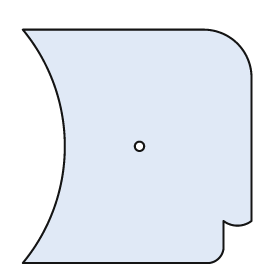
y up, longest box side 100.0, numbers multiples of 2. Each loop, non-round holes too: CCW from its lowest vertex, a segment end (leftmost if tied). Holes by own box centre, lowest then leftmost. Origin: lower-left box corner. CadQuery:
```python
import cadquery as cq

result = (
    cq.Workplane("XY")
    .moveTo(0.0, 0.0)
    .lineTo(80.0, 0.0)
    .threePointArc((84.0, 2.0), (86.0, 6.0))
    .lineTo(86.0, 18.0)
    .threePointArc((92.0, 16.0), (98.0, 18.0))
    .lineTo(98.0, 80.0)
    .threePointArc((92.0, 94.0), (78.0, 100.0))
    .lineTo(0.0, 100.0)
    .threePointArc((18.0, 50.0), (0.0, 0.0))
    .close()
    .moveTo(50.0, 50.0)
    .circle(2.0)
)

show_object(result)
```